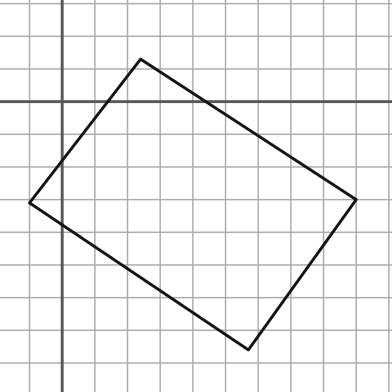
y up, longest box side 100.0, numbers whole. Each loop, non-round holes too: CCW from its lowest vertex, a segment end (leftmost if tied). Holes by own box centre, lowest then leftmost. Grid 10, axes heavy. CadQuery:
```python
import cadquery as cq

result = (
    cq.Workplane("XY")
    .moveTo(57.0, -76.0)
    .lineTo(90.0, -30.0)
    .lineTo(24.0, 13.0)
    .lineTo(-10.0, -31.0)
    .close()
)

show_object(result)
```